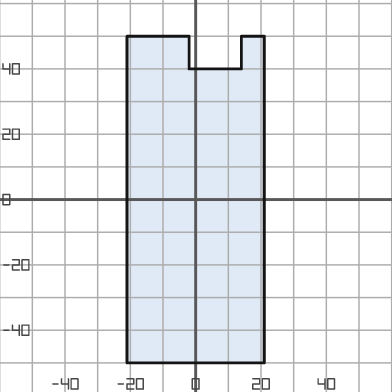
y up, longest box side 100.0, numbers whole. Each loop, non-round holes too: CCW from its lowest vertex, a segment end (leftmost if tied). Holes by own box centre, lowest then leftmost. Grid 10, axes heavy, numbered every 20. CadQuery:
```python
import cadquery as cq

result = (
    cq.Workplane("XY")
    .moveTo(-21.0, -50.0)
    .lineTo(21.0, -50.0)
    .lineTo(21.0, 50.0)
    .lineTo(14.0, 50.0)
    .lineTo(14.0, 40.0)
    .lineTo(-2.0, 40.0)
    .lineTo(-2.0, 50.0)
    .lineTo(-21.0, 50.0)
    .close()
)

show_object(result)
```